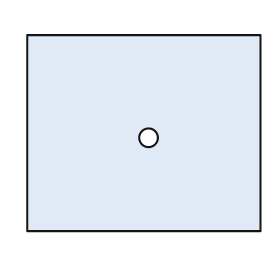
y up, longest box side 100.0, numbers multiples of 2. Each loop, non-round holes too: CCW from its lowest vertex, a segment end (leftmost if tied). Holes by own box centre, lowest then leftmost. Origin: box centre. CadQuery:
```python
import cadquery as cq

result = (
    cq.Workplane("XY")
    .moveTo(-50.0, -42.0)
    .lineTo(50.0, -42.0)
    .lineTo(50.0, 42.0)
    .lineTo(-50.0, 42.0)
    .close()
    .moveTo(2.0, -2.0)
    .circle(4.0)
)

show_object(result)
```